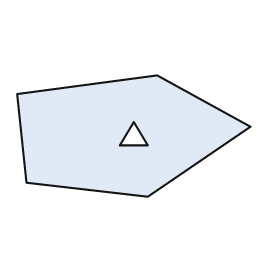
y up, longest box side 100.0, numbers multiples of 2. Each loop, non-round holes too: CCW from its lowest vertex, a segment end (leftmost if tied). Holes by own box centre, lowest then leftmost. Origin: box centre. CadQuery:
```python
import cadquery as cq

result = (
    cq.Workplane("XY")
    .moveTo(6.0, -26.0)
    .lineTo(50.0, 4.0)
    .lineTo(10.0, 26.0)
    .lineTo(-50.0, 18.0)
    .lineTo(-46.0, -20.0)
    .close()
    .moveTo(-6.0, -4.0)
    .lineTo(6.0, -4.0)
    .lineTo(0.0, 6.0)
    .close()
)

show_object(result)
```